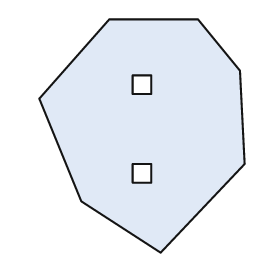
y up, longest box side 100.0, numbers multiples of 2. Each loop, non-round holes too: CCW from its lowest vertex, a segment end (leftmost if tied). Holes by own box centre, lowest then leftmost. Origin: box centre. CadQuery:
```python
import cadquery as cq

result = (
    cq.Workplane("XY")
    .moveTo(8.0, -50.0)
    .lineTo(44.0, -12.0)
    .lineTo(42.0, 28.0)
    .lineTo(24.0, 50.0)
    .lineTo(-14.0, 50.0)
    .lineTo(-44.0, 16.0)
    .lineTo(-26.0, -28.0)
    .close()
    .moveTo(-4.0, -20.0)
    .lineTo(4.0, -20.0)
    .lineTo(4.0, -12.0)
    .lineTo(-4.0, -12.0)
    .close()
    .moveTo(-4.0, 18.0)
    .lineTo(4.0, 18.0)
    .lineTo(4.0, 26.0)
    .lineTo(-4.0, 26.0)
    .close()
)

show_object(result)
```